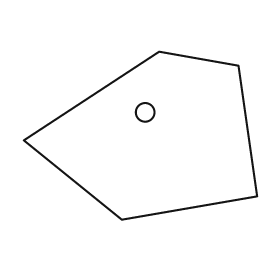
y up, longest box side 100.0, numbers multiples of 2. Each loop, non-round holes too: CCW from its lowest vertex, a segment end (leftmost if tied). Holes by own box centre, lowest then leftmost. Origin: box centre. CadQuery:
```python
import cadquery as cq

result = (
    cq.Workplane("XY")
    .moveTo(-8.0, -36.0)
    .lineTo(50.0, -26.0)
    .lineTo(42.0, 30.0)
    .lineTo(8.0, 36.0)
    .lineTo(-50.0, -2.0)
    .close()
    .moveTo(2.0, 10.0)
    .circle(4.0)
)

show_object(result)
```